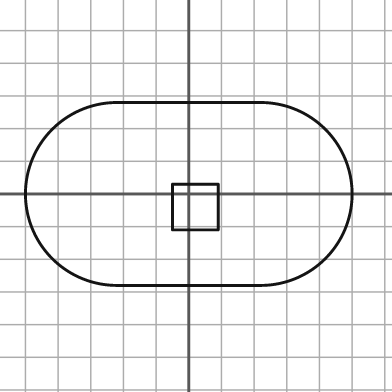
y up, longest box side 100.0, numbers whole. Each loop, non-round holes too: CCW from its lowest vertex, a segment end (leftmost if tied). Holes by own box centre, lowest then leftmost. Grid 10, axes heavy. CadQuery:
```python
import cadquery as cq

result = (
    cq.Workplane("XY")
    .moveTo(-22.0, -28.0)
    .lineTo(22.0, -28.0)
    .threePointArc((50.0, 0.0), (22.0, 28.0))
    .lineTo(-22.0, 28.0)
    .threePointArc((-50.0, 0.0), (-22.0, -28.0))
    .close()
    .moveTo(-5.0, -11.0)
    .lineTo(9.0, -11.0)
    .lineTo(9.0, 3.0)
    .lineTo(-5.0, 3.0)
    .close()
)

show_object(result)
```